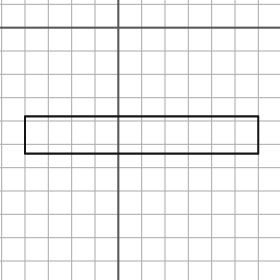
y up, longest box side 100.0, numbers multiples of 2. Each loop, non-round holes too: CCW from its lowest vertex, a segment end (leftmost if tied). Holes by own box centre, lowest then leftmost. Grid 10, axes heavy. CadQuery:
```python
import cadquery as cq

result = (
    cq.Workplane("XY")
    .moveTo(-40.0, -54.0)
    .lineTo(60.0, -54.0)
    .lineTo(60.0, -38.0)
    .lineTo(-40.0, -38.0)
    .close()
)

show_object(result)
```